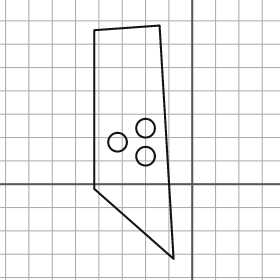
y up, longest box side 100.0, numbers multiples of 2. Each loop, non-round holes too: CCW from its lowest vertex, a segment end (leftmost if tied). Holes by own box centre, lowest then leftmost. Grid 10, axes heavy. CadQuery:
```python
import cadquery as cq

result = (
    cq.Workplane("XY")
    .moveTo(-8.0, -32.0)
    .lineTo(-14.0, 68.0)
    .lineTo(-42.0, 66.0)
    .lineTo(-42.0, -2.0)
    .close()
    .moveTo(-20.0, 12.0)
    .circle(4.0)
    .moveTo(-32.0, 18.0)
    .circle(4.0)
    .moveTo(-20.0, 24.0)
    .circle(4.0)
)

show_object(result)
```